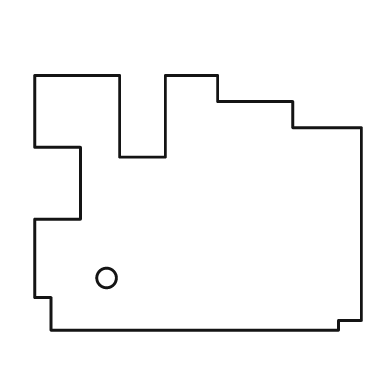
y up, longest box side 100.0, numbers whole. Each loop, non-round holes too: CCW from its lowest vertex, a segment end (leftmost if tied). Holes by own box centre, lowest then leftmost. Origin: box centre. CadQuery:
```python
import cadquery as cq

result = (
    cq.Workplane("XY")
    .moveTo(-45.0, -39.0)
    .lineTo(43.0, -39.0)
    .lineTo(43.0, -36.0)
    .lineTo(50.0, -36.0)
    .lineTo(50.0, 23.0)
    .lineTo(29.0, 23.0)
    .lineTo(29.0, 31.0)
    .lineTo(6.0, 31.0)
    .lineTo(6.0, 39.0)
    .lineTo(-10.0, 39.0)
    .lineTo(-10.0, 14.0)
    .lineTo(-24.0, 14.0)
    .lineTo(-24.0, 39.0)
    .lineTo(-50.0, 39.0)
    .lineTo(-50.0, 17.0)
    .lineTo(-36.0, 17.0)
    .lineTo(-36.0, -5.0)
    .lineTo(-50.0, -5.0)
    .lineTo(-50.0, -29.0)
    .lineTo(-45.0, -29.0)
    .close()
    .moveTo(-28.0, -23.0)
    .circle(3.0)
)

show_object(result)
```